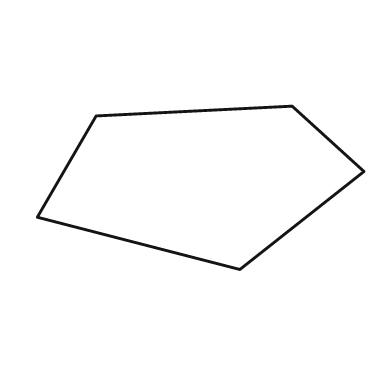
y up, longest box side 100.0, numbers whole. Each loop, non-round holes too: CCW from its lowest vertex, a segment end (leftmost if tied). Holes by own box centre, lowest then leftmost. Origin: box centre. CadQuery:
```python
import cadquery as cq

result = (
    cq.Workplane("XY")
    .moveTo(12.0, -25.0)
    .lineTo(50.0, 5.0)
    .lineTo(28.0, 25.0)
    .lineTo(-32.0, 22.0)
    .lineTo(-50.0, -9.0)
    .close()
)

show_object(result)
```